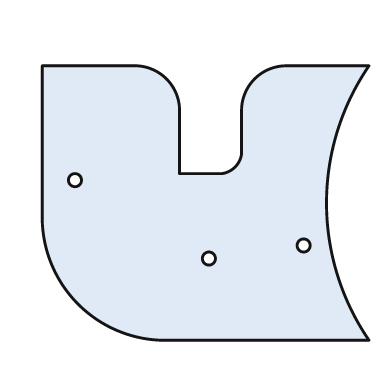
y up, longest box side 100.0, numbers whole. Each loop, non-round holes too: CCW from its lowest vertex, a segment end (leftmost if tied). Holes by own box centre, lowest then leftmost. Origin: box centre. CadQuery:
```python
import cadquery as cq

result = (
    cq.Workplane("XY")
    .moveTo(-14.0, -42.0)
    .lineTo(50.0, -42.0)
    .threePointArc((37.0, 0.0), (50.0, 42.0))
    .lineTo(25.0, 42.0)
    .threePointArc((15.0, 38.0), (11.0, 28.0))
    .lineTo(11.0, 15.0)
    .threePointArc((9.0, 11.0), (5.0, 9.0))
    .lineTo(-8.0, 9.0)
    .lineTo(-8.0, 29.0)
    .threePointArc((-12.0, 38.0), (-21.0, 42.0))
    .lineTo(-50.0, 42.0)
    .lineTo(-50.0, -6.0)
    .threePointArc((-39.0, -31.0), (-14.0, -42.0))
    .close()
    .moveTo(1.0, -17.0)
    .circle(2.0)
    .moveTo(30.0, -13.0)
    .circle(2.0)
    .moveTo(-40.0, 7.0)
    .circle(2.0)
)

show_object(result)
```